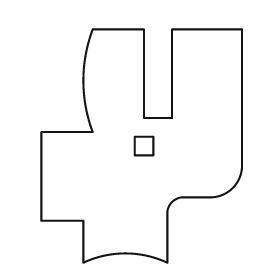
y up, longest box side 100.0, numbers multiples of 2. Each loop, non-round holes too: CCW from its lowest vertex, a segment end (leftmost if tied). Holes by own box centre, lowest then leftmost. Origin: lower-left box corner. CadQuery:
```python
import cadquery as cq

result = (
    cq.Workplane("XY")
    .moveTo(18.0, 0.0)
    .threePointArc((36.0, 4.0), (54.0, 0.0))
    .lineTo(54.0, 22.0)
    .threePointArc((56.0, 26.0), (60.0, 28.0))
    .lineTo(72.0, 28.0)
    .threePointArc((82.0, 32.0), (86.0, 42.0))
    .lineTo(86.0, 100.0)
    .lineTo(56.0, 100.0)
    .lineTo(56.0, 62.0)
    .lineTo(44.0, 62.0)
    .lineTo(44.0, 100.0)
    .lineTo(22.0, 100.0)
    .threePointArc((18.0, 78.0), (22.0, 56.0))
    .lineTo(0.0, 56.0)
    .lineTo(0.0, 18.0)
    .lineTo(18.0, 18.0)
    .close()
    .moveTo(40.0, 46.0)
    .lineTo(48.0, 46.0)
    .lineTo(48.0, 54.0)
    .lineTo(40.0, 54.0)
    .close()
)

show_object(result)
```